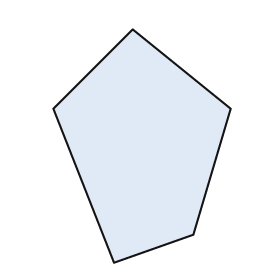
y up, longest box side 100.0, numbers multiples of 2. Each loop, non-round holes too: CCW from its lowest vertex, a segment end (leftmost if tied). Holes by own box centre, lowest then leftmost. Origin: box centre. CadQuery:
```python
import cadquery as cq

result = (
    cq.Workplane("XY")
    .moveTo(-12.0, -50.0)
    .lineTo(22.0, -38.0)
    .lineTo(38.0, 16.0)
    .lineTo(-4.0, 50.0)
    .lineTo(-38.0, 16.0)
    .close()
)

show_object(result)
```